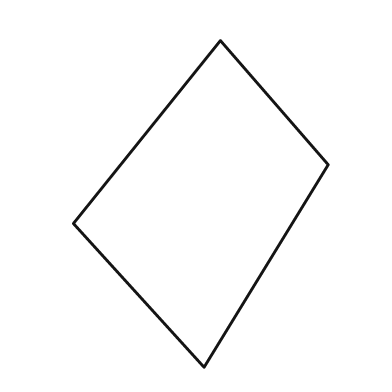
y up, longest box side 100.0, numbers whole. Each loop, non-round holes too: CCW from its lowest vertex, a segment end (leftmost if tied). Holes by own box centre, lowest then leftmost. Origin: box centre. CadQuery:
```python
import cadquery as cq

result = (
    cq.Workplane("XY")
    .moveTo(1.0, -50.0)
    .lineTo(39.0, 12.0)
    .lineTo(6.0, 50.0)
    .lineTo(-39.0, -6.0)
    .close()
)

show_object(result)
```